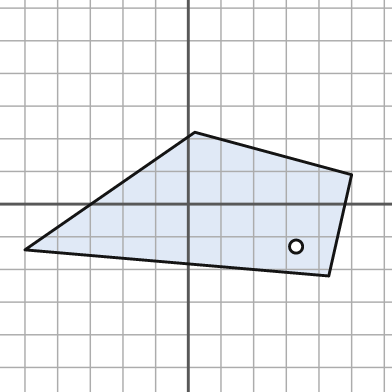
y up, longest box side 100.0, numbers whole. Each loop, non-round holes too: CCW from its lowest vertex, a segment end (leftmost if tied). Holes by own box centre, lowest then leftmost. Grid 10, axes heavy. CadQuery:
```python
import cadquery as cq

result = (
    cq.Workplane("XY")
    .moveTo(43.0, -22.0)
    .lineTo(50.0, 9.0)
    .lineTo(2.0, 22.0)
    .lineTo(-50.0, -14.0)
    .close()
    .moveTo(33.0, -13.0)
    .circle(2.0)
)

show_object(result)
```